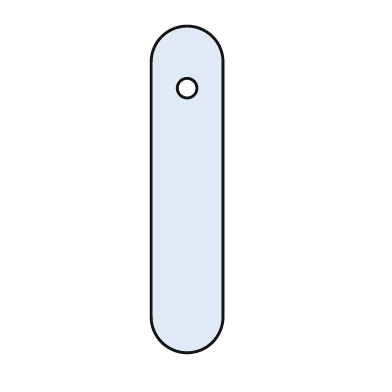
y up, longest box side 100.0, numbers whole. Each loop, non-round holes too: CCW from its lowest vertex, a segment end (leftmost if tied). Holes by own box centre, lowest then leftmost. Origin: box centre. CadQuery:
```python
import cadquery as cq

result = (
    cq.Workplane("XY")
    .moveTo(-11.0, -39.0)
    .threePointArc((0.0, -50.0), (11.0, -39.0))
    .lineTo(11.0, 39.0)
    .threePointArc((0.0, 50.0), (-11.0, 39.0))
    .close()
    .moveTo(0.0, 31.0)
    .circle(3.0)
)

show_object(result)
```